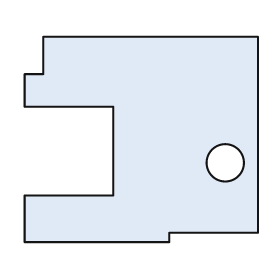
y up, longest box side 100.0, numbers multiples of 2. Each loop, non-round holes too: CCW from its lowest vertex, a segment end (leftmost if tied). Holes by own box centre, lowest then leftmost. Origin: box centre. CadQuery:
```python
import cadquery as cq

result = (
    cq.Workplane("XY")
    .moveTo(-50.0, -44.0)
    .lineTo(12.0, -44.0)
    .lineTo(12.0, -40.0)
    .lineTo(50.0, -40.0)
    .lineTo(50.0, 44.0)
    .lineTo(-42.0, 44.0)
    .lineTo(-42.0, 28.0)
    .lineTo(-50.0, 28.0)
    .lineTo(-50.0, 14.0)
    .lineTo(-12.0, 14.0)
    .lineTo(-12.0, -24.0)
    .lineTo(-50.0, -24.0)
    .close()
    .moveTo(36.0, -10.0)
    .circle(8.0)
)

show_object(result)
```